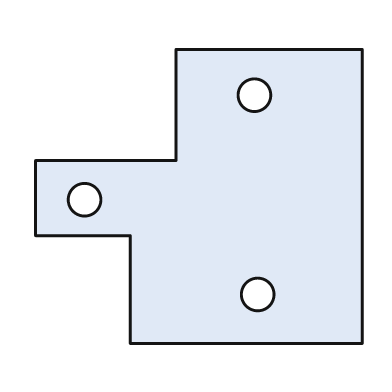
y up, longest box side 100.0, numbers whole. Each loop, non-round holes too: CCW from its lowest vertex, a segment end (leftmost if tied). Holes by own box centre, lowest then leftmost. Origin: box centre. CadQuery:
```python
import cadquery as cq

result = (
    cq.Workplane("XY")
    .moveTo(-21.0, -45.0)
    .lineTo(50.0, -45.0)
    .lineTo(50.0, 45.0)
    .lineTo(-7.0, 45.0)
    .lineTo(-7.0, 11.0)
    .lineTo(-50.0, 11.0)
    .lineTo(-50.0, -12.0)
    .lineTo(-21.0, -12.0)
    .close()
    .moveTo(18.0, -30.0)
    .circle(5.0)
    .moveTo(-35.0, -1.0)
    .circle(5.0)
    .moveTo(17.0, 31.0)
    .circle(5.0)
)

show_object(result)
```